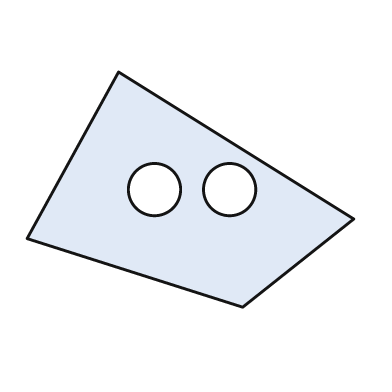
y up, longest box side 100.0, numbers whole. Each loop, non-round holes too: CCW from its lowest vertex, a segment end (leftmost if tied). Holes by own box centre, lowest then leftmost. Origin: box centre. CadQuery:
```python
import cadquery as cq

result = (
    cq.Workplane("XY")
    .moveTo(16.0, -36.0)
    .lineTo(50.0, -9.0)
    .lineTo(-22.0, 36.0)
    .lineTo(-50.0, -15.0)
    .close()
    .moveTo(-11.0, 0.0)
    .circle(8.0)
    .moveTo(12.0, 0.0)
    .circle(8.0)
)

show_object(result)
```